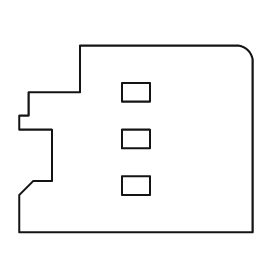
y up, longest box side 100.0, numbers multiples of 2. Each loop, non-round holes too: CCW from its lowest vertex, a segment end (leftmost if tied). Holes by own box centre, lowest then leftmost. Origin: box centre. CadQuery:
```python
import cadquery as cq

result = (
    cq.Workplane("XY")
    .moveTo(-50.0, -40.0)
    .lineTo(50.0, -40.0)
    .lineTo(50.0, 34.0)
    .threePointArc((48.0, 38.0), (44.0, 40.0))
    .lineTo(-24.0, 40.0)
    .lineTo(-24.0, 20.0)
    .lineTo(-46.0, 20.0)
    .lineTo(-46.0, 10.0)
    .lineTo(-50.0, 10.0)
    .lineTo(-50.0, 4.0)
    .lineTo(-36.0, 4.0)
    .lineTo(-36.0, -18.0)
    .lineTo(-44.0, -18.0)
    .lineTo(-50.0, -24.0)
    .close()
    .moveTo(-6.0, -24.0)
    .lineTo(6.0, -24.0)
    .lineTo(6.0, -16.0)
    .lineTo(-6.0, -16.0)
    .close()
    .moveTo(-6.0, -4.0)
    .lineTo(6.0, -4.0)
    .lineTo(6.0, 4.0)
    .lineTo(-6.0, 4.0)
    .close()
    .moveTo(-6.0, 16.0)
    .lineTo(6.0, 16.0)
    .lineTo(6.0, 24.0)
    .lineTo(-6.0, 24.0)
    .close()
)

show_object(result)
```